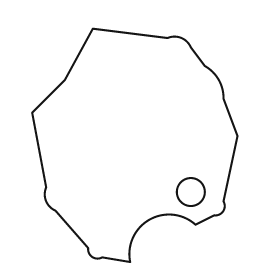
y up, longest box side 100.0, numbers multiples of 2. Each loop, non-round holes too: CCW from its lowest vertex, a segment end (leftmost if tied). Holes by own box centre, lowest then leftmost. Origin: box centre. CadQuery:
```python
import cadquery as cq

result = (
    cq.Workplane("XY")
    .moveTo(-2.0, -50.0)
    .threePointArc((6.0, -32.0), (26.0, -34.0))
    .lineTo(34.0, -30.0)
    .threePointArc((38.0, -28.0), (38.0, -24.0))
    .lineTo(44.0, 4.0)
    .lineTo(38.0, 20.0)
    .threePointArc((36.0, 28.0), (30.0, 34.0))
    .lineTo(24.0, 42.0)
    .threePointArc((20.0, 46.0), (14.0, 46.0))
    .lineTo(-18.0, 50.0)
    .lineTo(-30.0, 28.0)
    .lineTo(-44.0, 14.0)
    .lineTo(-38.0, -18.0)
    .threePointArc((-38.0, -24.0), (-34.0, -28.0))
    .lineTo(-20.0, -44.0)
    .threePointArc((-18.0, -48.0), (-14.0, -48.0))
    .close()
    .moveTo(24.0, -20.0)
    .circle(6.0)
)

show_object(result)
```